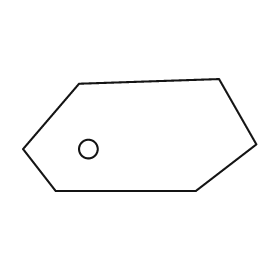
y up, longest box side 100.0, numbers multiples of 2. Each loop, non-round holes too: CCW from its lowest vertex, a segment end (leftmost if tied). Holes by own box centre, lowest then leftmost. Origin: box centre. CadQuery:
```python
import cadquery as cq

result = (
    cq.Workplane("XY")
    .moveTo(-36.0, -24.0)
    .lineTo(24.0, -24.0)
    .lineTo(50.0, -4.0)
    .lineTo(34.0, 24.0)
    .lineTo(-26.0, 22.0)
    .lineTo(-50.0, -6.0)
    .close()
    .moveTo(-22.0, -6.0)
    .circle(4.0)
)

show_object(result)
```